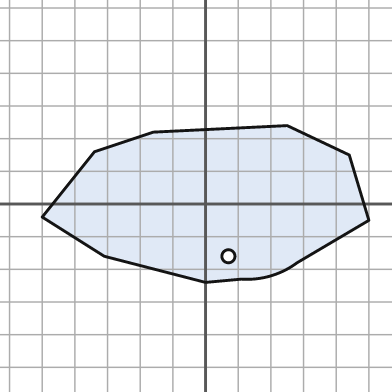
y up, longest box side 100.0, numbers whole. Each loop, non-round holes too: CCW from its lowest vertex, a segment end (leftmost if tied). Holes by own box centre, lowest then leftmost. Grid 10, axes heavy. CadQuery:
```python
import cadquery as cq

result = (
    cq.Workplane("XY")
    .moveTo(0.0, -24.0)
    .lineTo(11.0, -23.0)
    .threePointArc((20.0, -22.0), (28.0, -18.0))
    .lineTo(50.0, -5.0)
    .lineTo(44.0, 15.0)
    .lineTo(25.0, 24.0)
    .lineTo(-16.0, 22.0)
    .lineTo(-34.0, 16.0)
    .lineTo(-50.0, -4.0)
    .lineTo(-31.0, -16.0)
    .close()
    .moveTo(7.0, -16.0)
    .circle(2.0)
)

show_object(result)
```